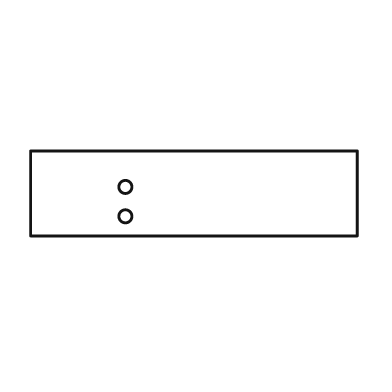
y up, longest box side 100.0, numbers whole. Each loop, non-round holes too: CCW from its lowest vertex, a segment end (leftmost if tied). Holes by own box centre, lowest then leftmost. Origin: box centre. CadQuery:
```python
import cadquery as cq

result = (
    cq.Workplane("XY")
    .moveTo(-50.0, -13.0)
    .lineTo(50.0, -13.0)
    .lineTo(50.0, 13.0)
    .lineTo(-50.0, 13.0)
    .close()
    .moveTo(-21.0, -7.0)
    .circle(2.0)
    .moveTo(-21.0, 2.0)
    .circle(2.0)
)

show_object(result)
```